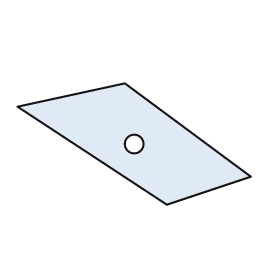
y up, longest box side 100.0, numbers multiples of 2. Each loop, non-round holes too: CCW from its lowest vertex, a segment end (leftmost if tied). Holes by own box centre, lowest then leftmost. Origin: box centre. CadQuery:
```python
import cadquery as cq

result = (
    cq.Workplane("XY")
    .moveTo(14.0, -26.0)
    .lineTo(50.0, -14.0)
    .lineTo(-4.0, 26.0)
    .lineTo(-50.0, 16.0)
    .close()
    .moveTo(0.0, 0.0)
    .circle(4.0)
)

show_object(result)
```